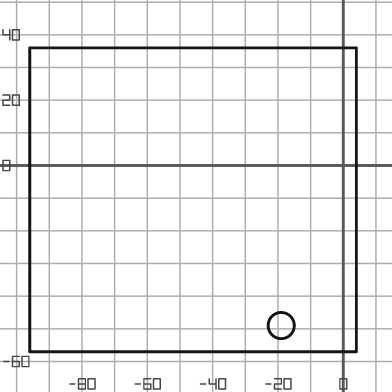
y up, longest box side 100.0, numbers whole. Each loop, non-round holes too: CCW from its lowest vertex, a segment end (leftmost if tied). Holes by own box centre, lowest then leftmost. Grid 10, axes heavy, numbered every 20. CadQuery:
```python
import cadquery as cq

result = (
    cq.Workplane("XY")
    .moveTo(-96.0, -57.0)
    .lineTo(4.0, -57.0)
    .lineTo(4.0, 36.0)
    .lineTo(-96.0, 36.0)
    .close()
    .moveTo(-19.0, -49.0)
    .circle(4.0)
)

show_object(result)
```